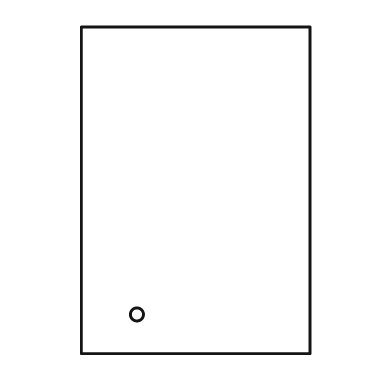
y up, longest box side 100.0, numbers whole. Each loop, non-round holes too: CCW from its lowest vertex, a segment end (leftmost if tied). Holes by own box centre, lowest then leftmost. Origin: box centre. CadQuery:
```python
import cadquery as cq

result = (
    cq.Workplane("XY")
    .moveTo(-35.0, -50.0)
    .lineTo(35.0, -50.0)
    .lineTo(35.0, 50.0)
    .lineTo(-35.0, 50.0)
    .close()
    .moveTo(-18.0, -38.0)
    .circle(2.0)
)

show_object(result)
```